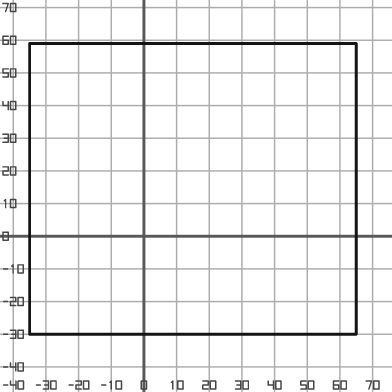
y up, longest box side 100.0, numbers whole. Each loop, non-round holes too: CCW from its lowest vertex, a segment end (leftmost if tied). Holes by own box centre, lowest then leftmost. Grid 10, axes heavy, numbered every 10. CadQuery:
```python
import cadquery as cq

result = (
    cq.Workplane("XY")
    .moveTo(-35.0, -30.0)
    .lineTo(65.0, -30.0)
    .lineTo(65.0, 59.0)
    .lineTo(-35.0, 59.0)
    .close()
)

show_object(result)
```